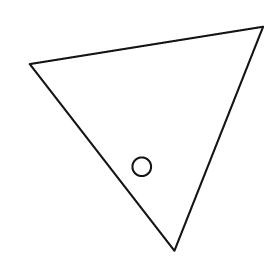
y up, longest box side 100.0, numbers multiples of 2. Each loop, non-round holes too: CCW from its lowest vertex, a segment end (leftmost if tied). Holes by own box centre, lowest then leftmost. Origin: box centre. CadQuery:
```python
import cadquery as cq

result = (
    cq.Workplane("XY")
    .moveTo(12.0, -48.0)
    .lineTo(50.0, 48.0)
    .lineTo(-50.0, 32.0)
    .close()
    .moveTo(-2.0, -12.0)
    .circle(4.0)
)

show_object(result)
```